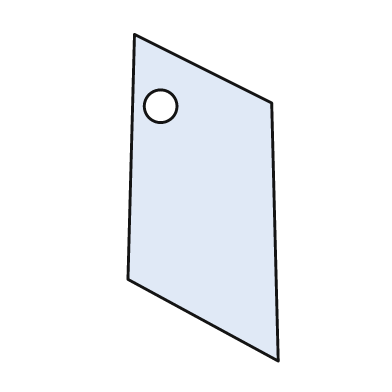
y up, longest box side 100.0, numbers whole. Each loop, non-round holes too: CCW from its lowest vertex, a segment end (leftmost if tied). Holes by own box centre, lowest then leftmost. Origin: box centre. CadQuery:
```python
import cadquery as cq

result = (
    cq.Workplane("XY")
    .moveTo(23.0, -50.0)
    .lineTo(21.0, 29.0)
    .lineTo(-21.0, 50.0)
    .lineTo(-23.0, -25.0)
    .close()
    .moveTo(-13.0, 28.0)
    .circle(5.0)
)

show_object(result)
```